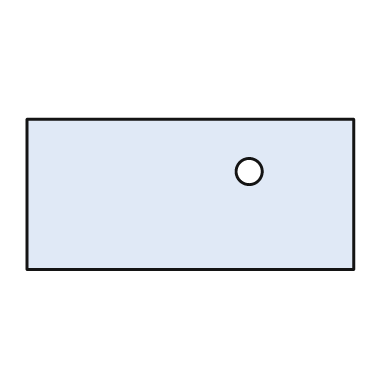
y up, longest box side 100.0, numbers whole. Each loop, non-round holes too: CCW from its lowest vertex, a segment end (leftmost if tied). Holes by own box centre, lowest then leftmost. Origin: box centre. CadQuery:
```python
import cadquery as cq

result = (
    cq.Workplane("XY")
    .moveTo(-50.0, -23.0)
    .lineTo(50.0, -23.0)
    .lineTo(50.0, 23.0)
    .lineTo(-50.0, 23.0)
    .close()
    .moveTo(18.0, 7.0)
    .circle(4.0)
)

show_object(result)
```